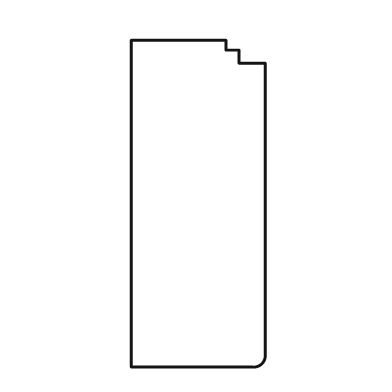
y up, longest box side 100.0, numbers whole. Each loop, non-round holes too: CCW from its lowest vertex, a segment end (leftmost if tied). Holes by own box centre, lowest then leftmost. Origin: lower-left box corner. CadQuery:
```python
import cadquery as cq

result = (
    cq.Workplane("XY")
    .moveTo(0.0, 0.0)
    .lineTo(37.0, 0.0)
    .threePointArc((40.0, 1.0), (41.0, 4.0))
    .lineTo(41.0, 93.0)
    .lineTo(33.0, 93.0)
    .lineTo(33.0, 97.0)
    .lineTo(29.0, 97.0)
    .lineTo(29.0, 100.0)
    .lineTo(0.0, 100.0)
    .close()
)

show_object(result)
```